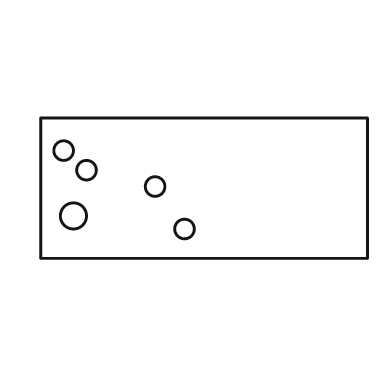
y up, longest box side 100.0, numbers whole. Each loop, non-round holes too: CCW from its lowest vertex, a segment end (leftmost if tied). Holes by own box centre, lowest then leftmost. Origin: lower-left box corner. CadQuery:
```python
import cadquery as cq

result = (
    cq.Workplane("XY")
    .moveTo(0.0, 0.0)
    .lineTo(100.0, 0.0)
    .lineTo(100.0, 43.0)
    .lineTo(0.0, 43.0)
    .close()
    .moveTo(44.0, 9.0)
    .circle(3.0)
    .moveTo(10.0, 13.0)
    .circle(4.0)
    .moveTo(35.0, 22.0)
    .circle(3.0)
    .moveTo(14.0, 27.0)
    .circle(3.0)
    .moveTo(7.0, 33.0)
    .circle(3.0)
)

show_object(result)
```